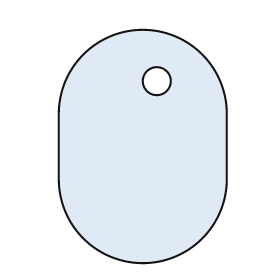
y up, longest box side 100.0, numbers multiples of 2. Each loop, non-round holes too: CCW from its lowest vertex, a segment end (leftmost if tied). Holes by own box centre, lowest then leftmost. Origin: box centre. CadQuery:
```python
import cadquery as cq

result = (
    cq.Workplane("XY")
    .moveTo(-36.0, -14.0)
    .threePointArc((0.0, -50.0), (36.0, -14.0))
    .lineTo(36.0, 14.0)
    .threePointArc((0.0, 50.0), (-36.0, 14.0))
    .close()
    .moveTo(6.0, 28.0)
    .circle(6.0)
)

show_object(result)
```